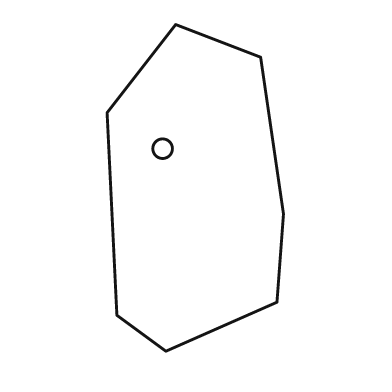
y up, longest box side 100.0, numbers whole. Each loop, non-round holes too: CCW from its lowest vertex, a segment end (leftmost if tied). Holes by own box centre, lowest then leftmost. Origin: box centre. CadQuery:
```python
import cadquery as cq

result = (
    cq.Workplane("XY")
    .moveTo(-9.0, -50.0)
    .lineTo(25.0, -35.0)
    .lineTo(27.0, -8.0)
    .lineTo(20.0, 40.0)
    .lineTo(-6.0, 50.0)
    .lineTo(-27.0, 23.0)
    .lineTo(-24.0, -39.0)
    .close()
    .moveTo(-10.0, 12.0)
    .circle(3.0)
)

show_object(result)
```